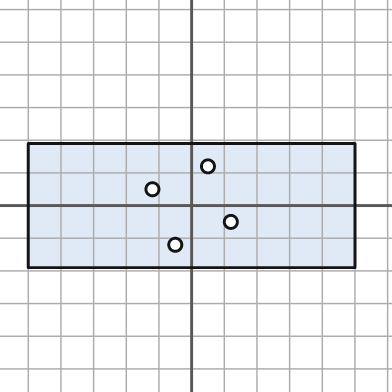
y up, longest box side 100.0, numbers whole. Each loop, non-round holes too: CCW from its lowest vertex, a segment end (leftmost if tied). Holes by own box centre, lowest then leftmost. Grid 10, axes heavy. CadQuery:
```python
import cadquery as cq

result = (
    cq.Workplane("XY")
    .moveTo(-50.0, -19.0)
    .lineTo(50.0, -19.0)
    .lineTo(50.0, 19.0)
    .lineTo(-50.0, 19.0)
    .close()
    .moveTo(-5.0, -12.0)
    .circle(2.0)
    .moveTo(12.0, -5.0)
    .circle(2.0)
    .moveTo(-12.0, 5.0)
    .circle(2.0)
    .moveTo(5.0, 12.0)
    .circle(2.0)
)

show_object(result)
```